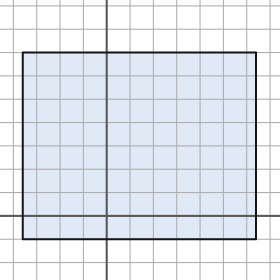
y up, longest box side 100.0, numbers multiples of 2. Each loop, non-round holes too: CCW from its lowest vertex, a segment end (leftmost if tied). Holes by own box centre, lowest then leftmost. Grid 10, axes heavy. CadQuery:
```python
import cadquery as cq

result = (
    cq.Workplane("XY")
    .moveTo(-36.0, -10.0)
    .lineTo(64.0, -10.0)
    .lineTo(64.0, 70.0)
    .lineTo(-36.0, 70.0)
    .close()
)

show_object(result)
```